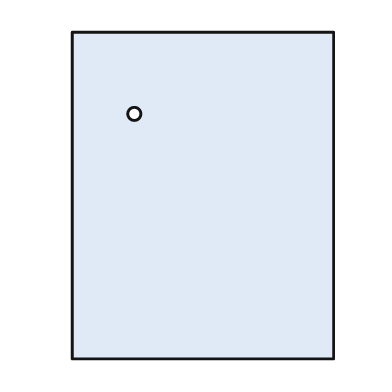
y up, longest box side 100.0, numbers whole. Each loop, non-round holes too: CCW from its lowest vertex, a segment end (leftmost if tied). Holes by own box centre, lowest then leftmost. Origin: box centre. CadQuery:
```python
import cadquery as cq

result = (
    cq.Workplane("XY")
    .moveTo(-40.0, -50.0)
    .lineTo(40.0, -50.0)
    .lineTo(40.0, 50.0)
    .lineTo(-40.0, 50.0)
    .close()
    .moveTo(-21.0, 25.0)
    .circle(2.0)
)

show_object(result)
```